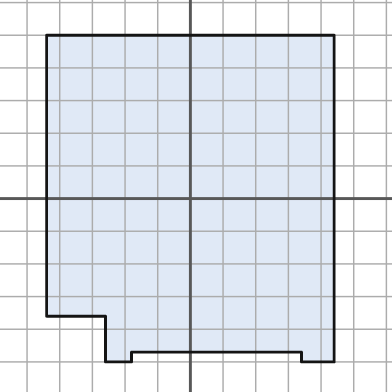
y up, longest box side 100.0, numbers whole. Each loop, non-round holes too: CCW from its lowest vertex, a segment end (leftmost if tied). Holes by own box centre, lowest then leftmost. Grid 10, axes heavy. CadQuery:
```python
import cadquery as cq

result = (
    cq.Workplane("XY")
    .moveTo(-26.0, -50.0)
    .lineTo(-18.0, -50.0)
    .lineTo(-18.0, -47.0)
    .lineTo(34.0, -47.0)
    .lineTo(34.0, -50.0)
    .lineTo(44.0, -50.0)
    .lineTo(44.0, 50.0)
    .lineTo(-44.0, 50.0)
    .lineTo(-44.0, -36.0)
    .lineTo(-26.0, -36.0)
    .close()
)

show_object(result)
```